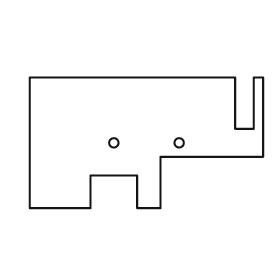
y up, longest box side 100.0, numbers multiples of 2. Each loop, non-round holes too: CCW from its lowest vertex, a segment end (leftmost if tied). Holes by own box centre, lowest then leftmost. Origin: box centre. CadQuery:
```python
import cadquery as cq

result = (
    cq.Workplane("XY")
    .moveTo(-50.0, -28.0)
    .lineTo(-24.0, -28.0)
    .lineTo(-24.0, -14.0)
    .lineTo(-4.0, -14.0)
    .lineTo(-4.0, -28.0)
    .lineTo(6.0, -28.0)
    .lineTo(6.0, -6.0)
    .lineTo(50.0, -6.0)
    .lineTo(50.0, 28.0)
    .lineTo(46.0, 28.0)
    .lineTo(46.0, 6.0)
    .lineTo(38.0, 6.0)
    .lineTo(38.0, 28.0)
    .lineTo(-50.0, 28.0)
    .close()
    .moveTo(-14.0, 0.0)
    .circle(2.0)
    .moveTo(14.0, 0.0)
    .circle(2.0)
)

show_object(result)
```